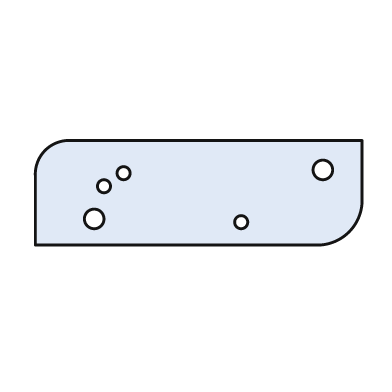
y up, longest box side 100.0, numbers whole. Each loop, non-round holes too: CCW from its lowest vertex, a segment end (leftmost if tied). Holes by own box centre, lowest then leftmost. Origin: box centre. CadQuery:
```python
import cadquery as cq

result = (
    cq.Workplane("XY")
    .moveTo(-50.0, -16.0)
    .lineTo(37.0, -16.0)
    .threePointArc((46.0, -12.0), (50.0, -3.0))
    .lineTo(50.0, 16.0)
    .lineTo(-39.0, 16.0)
    .threePointArc((-47.0, 13.0), (-50.0, 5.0))
    .close()
    .moveTo(13.0, -9.0)
    .circle(2.0)
    .moveTo(-32.0, -8.0)
    .circle(3.0)
    .moveTo(-29.0, 2.0)
    .circle(2.0)
    .moveTo(-23.0, 6.0)
    .circle(2.0)
    .moveTo(38.0, 7.0)
    .circle(3.0)
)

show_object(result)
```